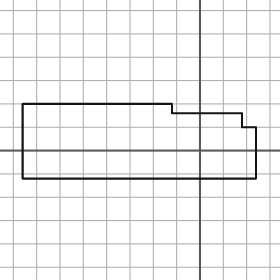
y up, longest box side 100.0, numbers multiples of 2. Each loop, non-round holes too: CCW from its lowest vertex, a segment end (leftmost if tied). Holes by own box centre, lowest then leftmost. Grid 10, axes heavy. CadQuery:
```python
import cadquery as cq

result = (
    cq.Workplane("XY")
    .moveTo(-76.0, -12.0)
    .lineTo(24.0, -12.0)
    .lineTo(24.0, 10.0)
    .lineTo(18.0, 10.0)
    .lineTo(18.0, 16.0)
    .lineTo(-12.0, 16.0)
    .lineTo(-12.0, 20.0)
    .lineTo(-76.0, 20.0)
    .close()
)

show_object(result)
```